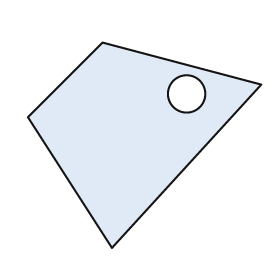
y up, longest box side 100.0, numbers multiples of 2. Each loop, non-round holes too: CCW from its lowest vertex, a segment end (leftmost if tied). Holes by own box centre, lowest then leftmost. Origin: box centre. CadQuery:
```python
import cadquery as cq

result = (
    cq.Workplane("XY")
    .moveTo(-14.0, -44.0)
    .lineTo(50.0, 26.0)
    .lineTo(-18.0, 44.0)
    .lineTo(-50.0, 12.0)
    .close()
    .moveTo(18.0, 22.0)
    .circle(8.0)
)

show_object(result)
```